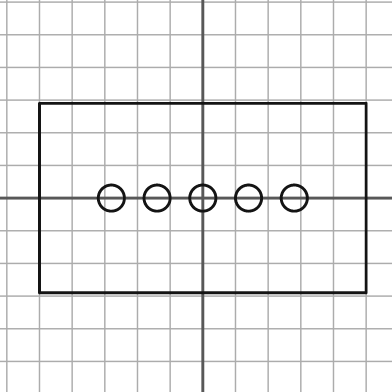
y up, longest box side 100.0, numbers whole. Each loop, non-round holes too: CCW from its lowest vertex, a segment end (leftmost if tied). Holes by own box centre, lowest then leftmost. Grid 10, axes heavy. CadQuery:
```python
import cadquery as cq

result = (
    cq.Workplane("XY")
    .moveTo(-50.0, -29.0)
    .lineTo(50.0, -29.0)
    .lineTo(50.0, 29.0)
    .lineTo(-50.0, 29.0)
    .close()
    .moveTo(-28.0, 0.0)
    .circle(4.0)
    .moveTo(-14.0, 0.0)
    .circle(4.0)
    .moveTo(0.0, 0.0)
    .circle(4.0)
    .moveTo(14.0, 0.0)
    .circle(4.0)
    .moveTo(28.0, 0.0)
    .circle(4.0)
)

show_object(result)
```